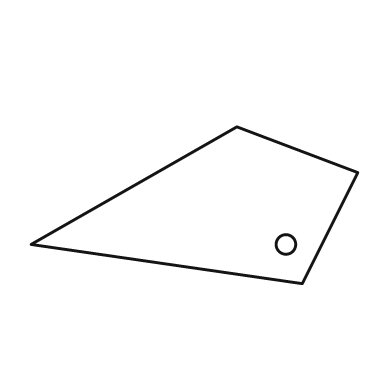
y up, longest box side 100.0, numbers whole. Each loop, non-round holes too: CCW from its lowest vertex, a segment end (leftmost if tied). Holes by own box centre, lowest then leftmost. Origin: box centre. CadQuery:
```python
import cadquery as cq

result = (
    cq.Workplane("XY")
    .moveTo(33.0, -24.0)
    .lineTo(50.0, 10.0)
    .lineTo(13.0, 24.0)
    .lineTo(-50.0, -12.0)
    .close()
    .moveTo(28.0, -12.0)
    .circle(3.0)
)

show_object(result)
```